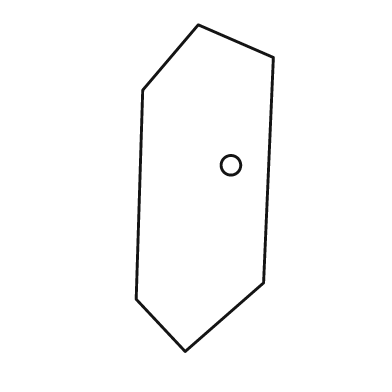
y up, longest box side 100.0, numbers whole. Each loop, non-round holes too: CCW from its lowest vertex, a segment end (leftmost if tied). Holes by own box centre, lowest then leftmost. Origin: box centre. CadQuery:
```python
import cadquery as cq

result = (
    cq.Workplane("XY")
    .moveTo(-6.0, -50.0)
    .lineTo(18.0, -29.0)
    .lineTo(21.0, 40.0)
    .lineTo(-2.0, 50.0)
    .lineTo(-19.0, 30.0)
    .lineTo(-21.0, -34.0)
    .close()
    .moveTo(8.0, 7.0)
    .circle(3.0)
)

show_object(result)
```